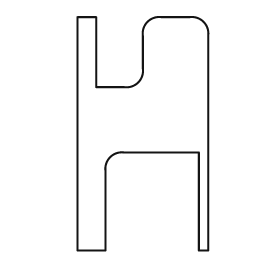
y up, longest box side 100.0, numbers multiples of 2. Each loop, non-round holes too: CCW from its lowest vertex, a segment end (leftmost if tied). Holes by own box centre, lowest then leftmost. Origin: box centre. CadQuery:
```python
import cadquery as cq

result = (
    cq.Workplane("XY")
    .moveTo(-28.0, -50.0)
    .lineTo(-16.0, -50.0)
    .lineTo(-16.0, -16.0)
    .threePointArc((-14.0, -10.0), (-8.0, -8.0))
    .lineTo(24.0, -8.0)
    .lineTo(24.0, -50.0)
    .lineTo(28.0, -50.0)
    .lineTo(28.0, 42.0)
    .threePointArc((26.0, 48.0), (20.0, 50.0))
    .lineTo(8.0, 50.0)
    .threePointArc((2.0, 48.0), (0.0, 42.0))
    .lineTo(0.0, 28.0)
    .threePointArc((-2.0, 22.0), (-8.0, 20.0))
    .lineTo(-20.0, 20.0)
    .lineTo(-20.0, 50.0)
    .lineTo(-28.0, 50.0)
    .close()
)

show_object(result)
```